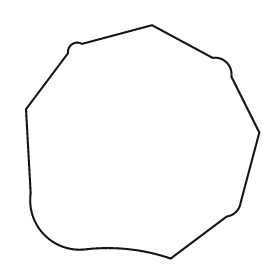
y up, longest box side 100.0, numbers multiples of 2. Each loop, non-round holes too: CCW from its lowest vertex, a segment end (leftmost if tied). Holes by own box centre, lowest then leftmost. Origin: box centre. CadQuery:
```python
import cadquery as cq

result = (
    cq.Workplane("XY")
    .moveTo(12.0, -50.0)
    .lineTo(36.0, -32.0)
    .threePointArc((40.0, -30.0), (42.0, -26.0))
    .lineTo(50.0, 4.0)
    .lineTo(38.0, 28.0)
    .threePointArc((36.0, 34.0), (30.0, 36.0))
    .lineTo(4.0, 50.0)
    .lineTo(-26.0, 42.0)
    .threePointArc((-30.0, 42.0), (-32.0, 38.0))
    .lineTo(-50.0, 14.0)
    .lineTo(-48.0, -22.0)
    .threePointArc((-42.0, -40.0), (-24.0, -46.0))
    .threePointArc((-6.0, -46.0), (12.0, -50.0))
    .close()
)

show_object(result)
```